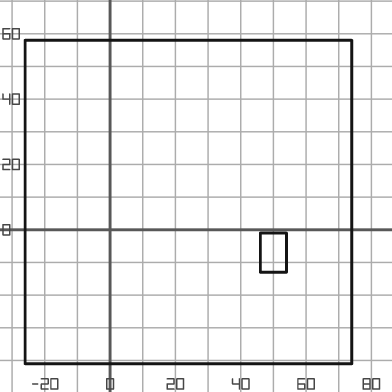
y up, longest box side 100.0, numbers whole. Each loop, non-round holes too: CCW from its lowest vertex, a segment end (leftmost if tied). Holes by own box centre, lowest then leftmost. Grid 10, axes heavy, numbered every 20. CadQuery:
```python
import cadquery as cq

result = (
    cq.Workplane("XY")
    .moveTo(-26.0, -41.0)
    .lineTo(74.0, -41.0)
    .lineTo(74.0, 58.0)
    .lineTo(-26.0, 58.0)
    .close()
    .moveTo(46.0, -13.0)
    .lineTo(54.0, -13.0)
    .lineTo(54.0, -1.0)
    .lineTo(46.0, -1.0)
    .close()
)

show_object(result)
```